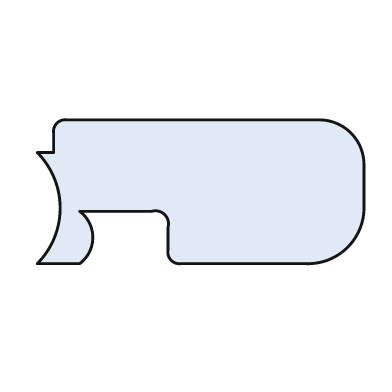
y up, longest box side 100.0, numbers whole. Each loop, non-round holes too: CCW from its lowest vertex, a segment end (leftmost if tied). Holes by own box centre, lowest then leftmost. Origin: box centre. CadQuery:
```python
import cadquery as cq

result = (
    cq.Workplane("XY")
    .moveTo(-50.0, -22.0)
    .lineTo(-37.0, -22.0)
    .threePointArc((-33.0, -14.0), (-37.0, -6.0))
    .lineTo(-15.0, -6.0)
    .threePointArc((-11.0, -7.0), (-10.0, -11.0))
    .lineTo(-10.0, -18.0)
    .threePointArc((-9.0, -21.0), (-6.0, -22.0))
    .lineTo(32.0, -22.0)
    .threePointArc((45.0, -17.0), (50.0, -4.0))
    .lineTo(50.0, 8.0)
    .threePointArc((46.0, 18.0), (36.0, 22.0))
    .lineTo(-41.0, 22.0)
    .threePointArc((-44.0, 21.0), (-45.0, 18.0))
    .lineTo(-45.0, 12.0)
    .lineTo(-50.0, 12.0)
    .threePointArc((-43.0, -5.0), (-50.0, -22.0))
    .close()
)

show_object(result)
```